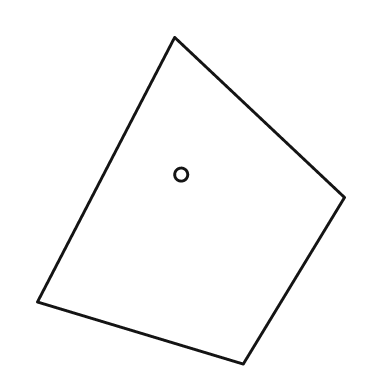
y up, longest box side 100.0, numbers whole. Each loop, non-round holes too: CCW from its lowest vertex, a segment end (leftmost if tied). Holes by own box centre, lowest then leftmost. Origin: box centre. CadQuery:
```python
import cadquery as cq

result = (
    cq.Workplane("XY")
    .moveTo(16.0, -50.0)
    .lineTo(47.0, 1.0)
    .lineTo(-5.0, 50.0)
    .lineTo(-47.0, -31.0)
    .close()
    .moveTo(-3.0, 8.0)
    .circle(2.0)
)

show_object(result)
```